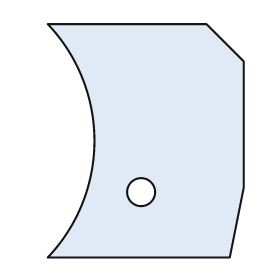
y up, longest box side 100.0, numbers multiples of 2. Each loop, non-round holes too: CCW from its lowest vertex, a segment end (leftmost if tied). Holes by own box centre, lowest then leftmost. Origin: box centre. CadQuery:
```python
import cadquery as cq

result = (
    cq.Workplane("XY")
    .moveTo(-42.0, -50.0)
    .lineTo(36.0, -50.0)
    .lineTo(42.0, -20.0)
    .lineTo(42.0, 34.0)
    .lineTo(26.0, 50.0)
    .lineTo(-42.0, 50.0)
    .threePointArc((-22.0, 0.0), (-42.0, -50.0))
    .close()
    .moveTo(-2.0, -22.0)
    .circle(6.0)
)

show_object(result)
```